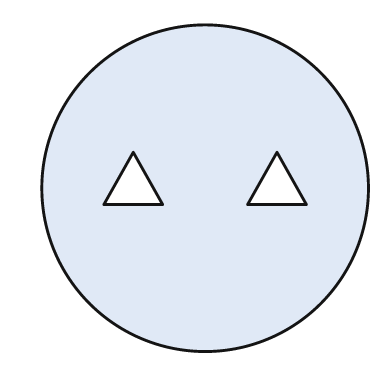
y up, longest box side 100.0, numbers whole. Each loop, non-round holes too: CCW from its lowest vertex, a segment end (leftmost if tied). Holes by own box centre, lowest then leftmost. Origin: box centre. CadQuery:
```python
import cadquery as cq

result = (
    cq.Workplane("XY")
    .moveTo(0.0, 0.0)
    .circle(50.0)
    .moveTo(-31.0, -5.0)
    .lineTo(-13.0, -5.0)
    .lineTo(-22.0, 11.0)
    .close()
    .moveTo(13.0, -5.0)
    .lineTo(31.0, -5.0)
    .lineTo(22.0, 11.0)
    .close()
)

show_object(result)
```